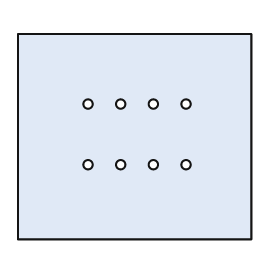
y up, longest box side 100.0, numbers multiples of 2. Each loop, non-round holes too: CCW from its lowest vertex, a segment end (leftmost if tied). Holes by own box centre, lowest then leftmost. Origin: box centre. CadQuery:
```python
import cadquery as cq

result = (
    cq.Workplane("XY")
    .moveTo(-50.0, -44.0)
    .lineTo(50.0, -44.0)
    .lineTo(50.0, 44.0)
    .lineTo(-50.0, 44.0)
    .close()
    .moveTo(-20.0, -12.0)
    .circle(2.0)
    .moveTo(-6.0, -12.0)
    .circle(2.0)
    .moveTo(8.0, -12.0)
    .circle(2.0)
    .moveTo(22.0, -12.0)
    .circle(2.0)
    .moveTo(-20.0, 14.0)
    .circle(2.0)
    .moveTo(-6.0, 14.0)
    .circle(2.0)
    .moveTo(8.0, 14.0)
    .circle(2.0)
    .moveTo(22.0, 14.0)
    .circle(2.0)
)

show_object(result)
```